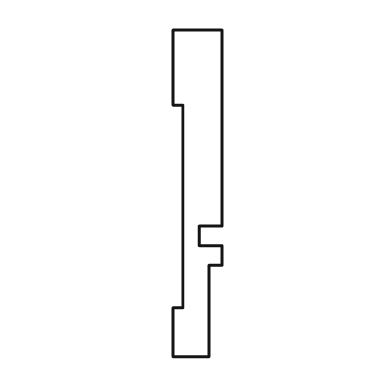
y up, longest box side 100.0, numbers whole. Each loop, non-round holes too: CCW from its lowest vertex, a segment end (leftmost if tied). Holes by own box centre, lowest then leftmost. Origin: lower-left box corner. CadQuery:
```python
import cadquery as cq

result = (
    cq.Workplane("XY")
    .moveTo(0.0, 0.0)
    .lineTo(11.0, 0.0)
    .lineTo(11.0, 28.0)
    .lineTo(15.0, 28.0)
    .lineTo(15.0, 34.0)
    .lineTo(8.0, 34.0)
    .lineTo(8.0, 40.0)
    .lineTo(15.0, 40.0)
    .lineTo(15.0, 100.0)
    .lineTo(0.0, 100.0)
    .lineTo(0.0, 77.0)
    .lineTo(3.0, 77.0)
    .lineTo(3.0, 15.0)
    .lineTo(0.0, 15.0)
    .close()
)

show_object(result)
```